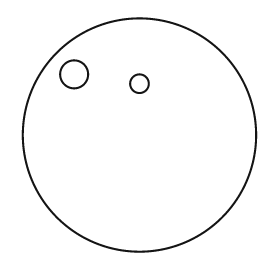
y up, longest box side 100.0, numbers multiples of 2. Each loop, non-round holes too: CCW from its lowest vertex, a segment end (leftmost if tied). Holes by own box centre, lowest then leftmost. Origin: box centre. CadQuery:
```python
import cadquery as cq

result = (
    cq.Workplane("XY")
    .moveTo(0.0, 0.0)
    .circle(50.0)
    .moveTo(0.0, 22.0)
    .circle(4.0)
    .moveTo(-28.0, 26.0)
    .circle(6.0)
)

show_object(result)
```